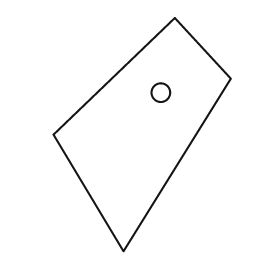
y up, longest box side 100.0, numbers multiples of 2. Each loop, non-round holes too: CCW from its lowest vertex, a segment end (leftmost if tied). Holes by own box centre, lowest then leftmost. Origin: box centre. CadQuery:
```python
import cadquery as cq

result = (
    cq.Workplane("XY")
    .moveTo(-8.0, -50.0)
    .lineTo(38.0, 24.0)
    .lineTo(14.0, 50.0)
    .lineTo(-38.0, 0.0)
    .close()
    .moveTo(8.0, 18.0)
    .circle(4.0)
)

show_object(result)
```